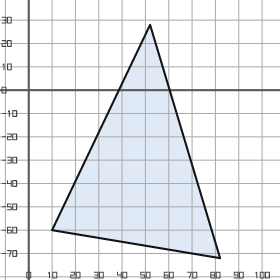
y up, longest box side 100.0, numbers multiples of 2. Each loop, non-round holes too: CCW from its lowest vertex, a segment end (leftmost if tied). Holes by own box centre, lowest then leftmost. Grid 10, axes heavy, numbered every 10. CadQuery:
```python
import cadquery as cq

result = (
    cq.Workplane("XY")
    .moveTo(82.0, -72.0)
    .lineTo(52.0, 28.0)
    .lineTo(10.0, -60.0)
    .close()
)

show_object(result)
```